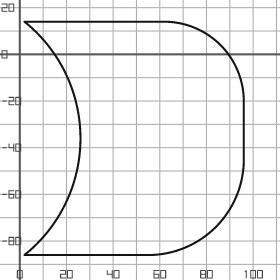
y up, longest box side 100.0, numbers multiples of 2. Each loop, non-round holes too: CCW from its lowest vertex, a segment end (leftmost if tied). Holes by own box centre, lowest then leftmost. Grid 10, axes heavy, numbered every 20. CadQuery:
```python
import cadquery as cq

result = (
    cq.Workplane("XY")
    .moveTo(2.0, -86.0)
    .lineTo(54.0, -86.0)
    .threePointArc((84.0, -74.0), (96.0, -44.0))
    .lineTo(96.0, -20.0)
    .threePointArc((86.0, 4.0), (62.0, 14.0))
    .lineTo(2.0, 14.0)
    .threePointArc((26.0, -36.0), (2.0, -86.0))
    .close()
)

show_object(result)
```